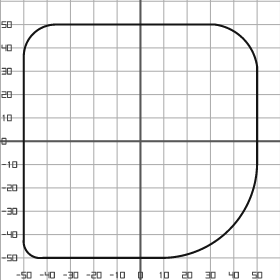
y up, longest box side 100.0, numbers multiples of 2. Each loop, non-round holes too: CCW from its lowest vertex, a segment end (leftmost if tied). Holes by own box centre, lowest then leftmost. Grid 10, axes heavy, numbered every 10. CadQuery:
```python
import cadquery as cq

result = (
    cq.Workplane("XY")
    .moveTo(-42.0, -50.0)
    .lineTo(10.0, -50.0)
    .threePointArc((38.0, -38.0), (50.0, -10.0))
    .lineTo(50.0, 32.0)
    .threePointArc((44.0, 44.0), (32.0, 50.0))
    .lineTo(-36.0, 50.0)
    .threePointArc((-46.0, 46.0), (-50.0, 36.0))
    .lineTo(-50.0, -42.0)
    .threePointArc((-48.0, -48.0), (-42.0, -50.0))
    .close()
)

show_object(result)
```